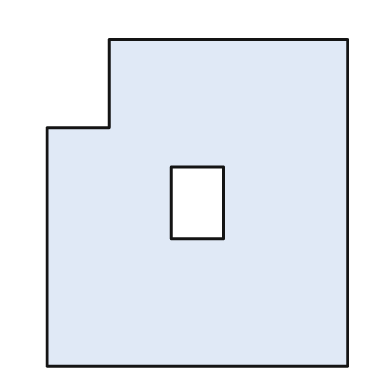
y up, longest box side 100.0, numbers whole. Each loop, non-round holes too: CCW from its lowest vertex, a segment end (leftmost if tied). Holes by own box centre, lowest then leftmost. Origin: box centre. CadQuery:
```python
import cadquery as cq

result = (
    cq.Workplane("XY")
    .moveTo(-46.0, -50.0)
    .lineTo(46.0, -50.0)
    .lineTo(46.0, 50.0)
    .lineTo(-27.0, 50.0)
    .lineTo(-27.0, 23.0)
    .lineTo(-46.0, 23.0)
    .close()
    .moveTo(-8.0, -11.0)
    .lineTo(8.0, -11.0)
    .lineTo(8.0, 11.0)
    .lineTo(-8.0, 11.0)
    .close()
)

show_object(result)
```